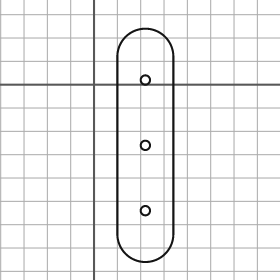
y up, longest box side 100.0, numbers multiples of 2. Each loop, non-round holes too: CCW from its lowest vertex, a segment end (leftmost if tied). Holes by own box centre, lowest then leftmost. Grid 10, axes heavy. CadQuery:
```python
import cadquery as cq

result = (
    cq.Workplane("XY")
    .moveTo(10.0, -64.0)
    .threePointArc((22.0, -76.0), (34.0, -64.0))
    .lineTo(34.0, 12.0)
    .threePointArc((22.0, 24.0), (10.0, 12.0))
    .close()
    .moveTo(22.0, -54.0)
    .circle(2.0)
    .moveTo(22.0, -26.0)
    .circle(2.0)
    .moveTo(22.0, 2.0)
    .circle(2.0)
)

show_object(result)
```